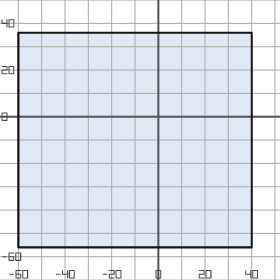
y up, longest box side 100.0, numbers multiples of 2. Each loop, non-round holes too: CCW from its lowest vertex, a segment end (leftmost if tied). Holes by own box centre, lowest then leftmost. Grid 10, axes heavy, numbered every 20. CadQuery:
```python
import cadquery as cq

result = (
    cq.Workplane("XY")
    .moveTo(-60.0, -56.0)
    .lineTo(40.0, -56.0)
    .lineTo(40.0, 36.0)
    .lineTo(-60.0, 36.0)
    .close()
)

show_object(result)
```